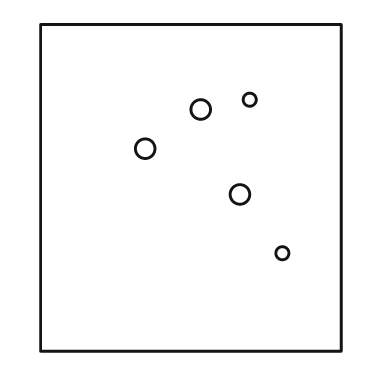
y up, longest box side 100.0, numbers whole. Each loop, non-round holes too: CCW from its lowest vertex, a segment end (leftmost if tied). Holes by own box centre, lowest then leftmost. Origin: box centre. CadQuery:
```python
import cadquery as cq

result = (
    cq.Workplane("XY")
    .moveTo(-46.0, -50.0)
    .lineTo(46.0, -50.0)
    .lineTo(46.0, 50.0)
    .lineTo(-46.0, 50.0)
    .close()
    .moveTo(28.0, -20.0)
    .circle(2.0)
    .moveTo(15.0, -2.0)
    .circle(3.0)
    .moveTo(-14.0, 12.0)
    .circle(3.0)
    .moveTo(3.0, 24.0)
    .circle(3.0)
    .moveTo(18.0, 27.0)
    .circle(2.0)
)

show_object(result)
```